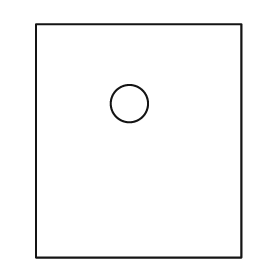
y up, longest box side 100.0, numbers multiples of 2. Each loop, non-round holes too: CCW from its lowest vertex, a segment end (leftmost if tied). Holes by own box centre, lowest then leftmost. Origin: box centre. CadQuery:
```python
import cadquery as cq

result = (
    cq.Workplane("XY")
    .moveTo(-44.0, -50.0)
    .lineTo(44.0, -50.0)
    .lineTo(44.0, 50.0)
    .lineTo(-44.0, 50.0)
    .close()
    .moveTo(-4.0, 16.0)
    .circle(8.0)
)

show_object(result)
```